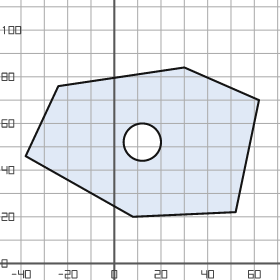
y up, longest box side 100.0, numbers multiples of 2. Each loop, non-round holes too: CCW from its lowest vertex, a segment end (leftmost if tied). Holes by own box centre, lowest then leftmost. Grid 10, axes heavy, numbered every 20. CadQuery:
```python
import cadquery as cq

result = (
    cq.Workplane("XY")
    .moveTo(8.0, 20.0)
    .lineTo(52.0, 22.0)
    .lineTo(62.0, 70.0)
    .lineTo(30.0, 84.0)
    .lineTo(-24.0, 76.0)
    .lineTo(-38.0, 46.0)
    .close()
    .moveTo(12.0, 52.0)
    .circle(8.0)
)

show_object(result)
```